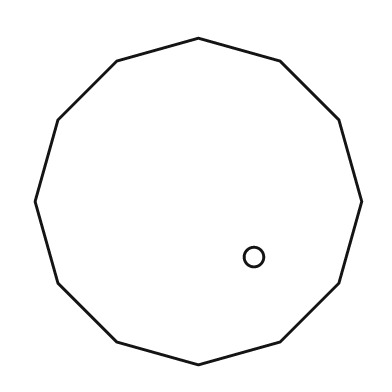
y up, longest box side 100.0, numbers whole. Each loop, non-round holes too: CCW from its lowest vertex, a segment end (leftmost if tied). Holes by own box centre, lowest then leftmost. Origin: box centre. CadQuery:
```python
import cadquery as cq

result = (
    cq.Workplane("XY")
    .moveTo(0.0, -50.0)
    .lineTo(25.0, -43.0)
    .lineTo(43.0, -25.0)
    .lineTo(50.0, 0.0)
    .lineTo(43.0, 25.0)
    .lineTo(25.0, 43.0)
    .lineTo(0.0, 50.0)
    .lineTo(-25.0, 43.0)
    .lineTo(-43.0, 25.0)
    .lineTo(-50.0, 0.0)
    .lineTo(-43.0, -25.0)
    .lineTo(-25.0, -43.0)
    .close()
    .moveTo(17.0, -17.0)
    .circle(3.0)
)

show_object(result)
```